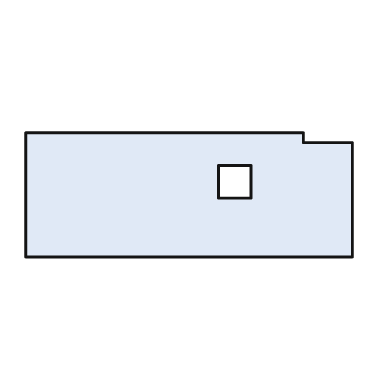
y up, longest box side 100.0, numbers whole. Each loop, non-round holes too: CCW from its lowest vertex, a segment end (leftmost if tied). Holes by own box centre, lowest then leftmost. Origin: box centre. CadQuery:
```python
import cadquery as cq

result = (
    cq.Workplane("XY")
    .moveTo(-50.0, -19.0)
    .lineTo(50.0, -19.0)
    .lineTo(50.0, 16.0)
    .lineTo(35.0, 16.0)
    .lineTo(35.0, 19.0)
    .lineTo(-50.0, 19.0)
    .close()
    .moveTo(9.0, -1.0)
    .lineTo(19.0, -1.0)
    .lineTo(19.0, 9.0)
    .lineTo(9.0, 9.0)
    .close()
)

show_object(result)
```